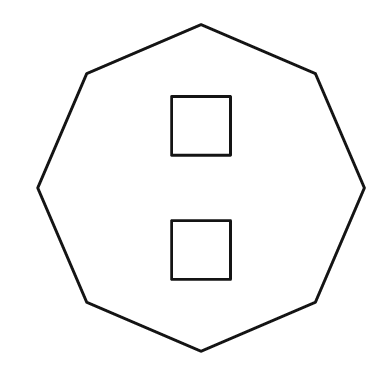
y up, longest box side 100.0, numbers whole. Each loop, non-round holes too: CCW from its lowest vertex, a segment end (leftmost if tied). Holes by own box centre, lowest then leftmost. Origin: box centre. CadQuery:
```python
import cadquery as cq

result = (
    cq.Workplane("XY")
    .moveTo(0.0, -50.0)
    .lineTo(35.0, -35.0)
    .lineTo(50.0, 0.0)
    .lineTo(35.0, 35.0)
    .lineTo(0.0, 50.0)
    .lineTo(-35.0, 35.0)
    .lineTo(-50.0, 0.0)
    .lineTo(-35.0, -35.0)
    .close()
    .moveTo(-9.0, -28.0)
    .lineTo(9.0, -28.0)
    .lineTo(9.0, -10.0)
    .lineTo(-9.0, -10.0)
    .close()
    .moveTo(-9.0, 10.0)
    .lineTo(9.0, 10.0)
    .lineTo(9.0, 28.0)
    .lineTo(-9.0, 28.0)
    .close()
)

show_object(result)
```